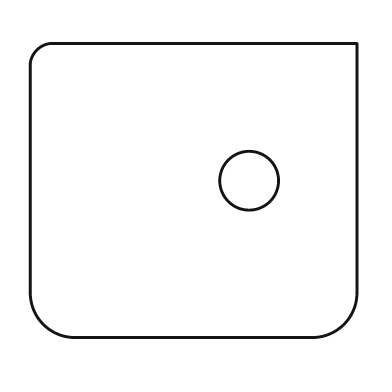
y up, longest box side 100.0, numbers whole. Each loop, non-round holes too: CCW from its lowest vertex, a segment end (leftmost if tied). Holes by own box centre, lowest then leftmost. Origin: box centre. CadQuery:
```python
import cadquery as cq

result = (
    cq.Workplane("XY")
    .moveTo(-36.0, -45.0)
    .lineTo(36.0, -45.0)
    .threePointArc((46.0, -41.0), (50.0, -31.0))
    .lineTo(50.0, 45.0)
    .lineTo(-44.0, 45.0)
    .threePointArc((-48.0, 43.0), (-50.0, 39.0))
    .lineTo(-50.0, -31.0)
    .threePointArc((-46.0, -41.0), (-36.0, -45.0))
    .close()
    .moveTo(17.0, 3.0)
    .circle(9.0)
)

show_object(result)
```